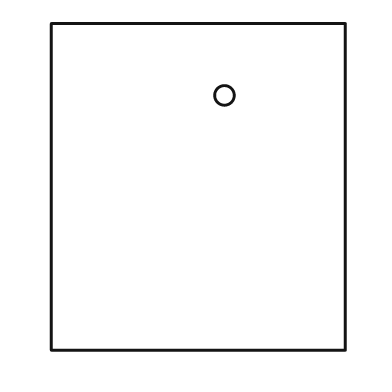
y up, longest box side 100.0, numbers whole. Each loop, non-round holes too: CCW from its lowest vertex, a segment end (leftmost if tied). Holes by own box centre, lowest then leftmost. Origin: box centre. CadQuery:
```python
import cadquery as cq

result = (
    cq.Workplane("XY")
    .moveTo(-45.0, -50.0)
    .lineTo(45.0, -50.0)
    .lineTo(45.0, 50.0)
    .lineTo(-45.0, 50.0)
    .close()
    .moveTo(8.0, 28.0)
    .circle(3.0)
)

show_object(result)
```